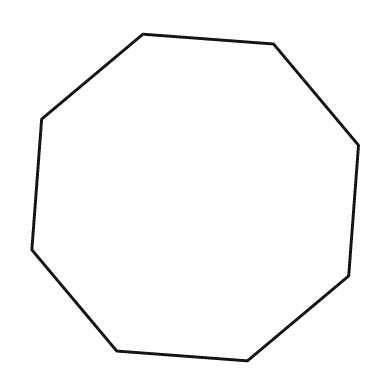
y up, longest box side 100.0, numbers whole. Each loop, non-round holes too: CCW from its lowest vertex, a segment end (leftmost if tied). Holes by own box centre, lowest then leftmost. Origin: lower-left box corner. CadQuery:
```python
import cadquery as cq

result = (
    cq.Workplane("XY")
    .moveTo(66.0, 0.0)
    .lineTo(97.0, 26.0)
    .lineTo(100.0, 66.0)
    .lineTo(74.0, 97.0)
    .lineTo(34.0, 100.0)
    .lineTo(3.0, 74.0)
    .lineTo(0.0, 34.0)
    .lineTo(26.0, 3.0)
    .close()
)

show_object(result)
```